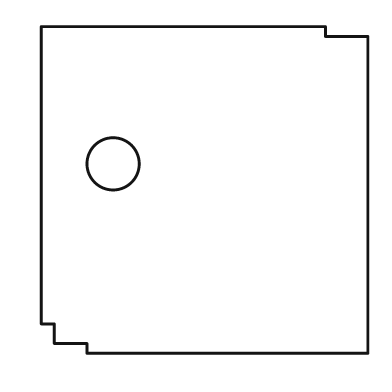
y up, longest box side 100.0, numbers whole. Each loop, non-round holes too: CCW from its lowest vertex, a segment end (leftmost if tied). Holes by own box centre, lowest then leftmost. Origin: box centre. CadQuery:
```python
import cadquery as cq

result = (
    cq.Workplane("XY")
    .moveTo(-36.0, -50.0)
    .lineTo(50.0, -50.0)
    .lineTo(50.0, 47.0)
    .lineTo(37.0, 47.0)
    .lineTo(37.0, 50.0)
    .lineTo(-50.0, 50.0)
    .lineTo(-50.0, -41.0)
    .lineTo(-46.0, -41.0)
    .lineTo(-46.0, -47.0)
    .lineTo(-36.0, -47.0)
    .close()
    .moveTo(-28.0, 8.0)
    .circle(8.0)
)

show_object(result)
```